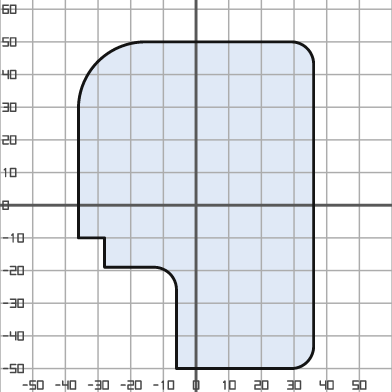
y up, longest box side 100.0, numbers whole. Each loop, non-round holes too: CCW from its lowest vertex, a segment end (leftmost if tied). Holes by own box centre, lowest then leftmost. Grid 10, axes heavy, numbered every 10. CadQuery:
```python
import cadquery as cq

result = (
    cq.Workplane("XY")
    .moveTo(-6.0, -50.0)
    .lineTo(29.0, -50.0)
    .threePointArc((34.0, -48.0), (36.0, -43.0))
    .lineTo(36.0, 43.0)
    .threePointArc((34.0, 48.0), (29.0, 50.0))
    .lineTo(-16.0, 50.0)
    .threePointArc((-30.0, 44.0), (-36.0, 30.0))
    .lineTo(-36.0, -10.0)
    .lineTo(-28.0, -10.0)
    .lineTo(-28.0, -19.0)
    .lineTo(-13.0, -19.0)
    .threePointArc((-8.0, -21.0), (-6.0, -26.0))
    .close()
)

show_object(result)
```